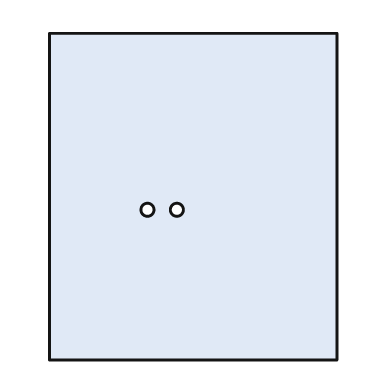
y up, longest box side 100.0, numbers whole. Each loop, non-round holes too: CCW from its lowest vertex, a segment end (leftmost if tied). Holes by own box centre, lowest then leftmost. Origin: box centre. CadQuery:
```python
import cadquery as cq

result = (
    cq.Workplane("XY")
    .moveTo(-44.0, -50.0)
    .lineTo(44.0, -50.0)
    .lineTo(44.0, 50.0)
    .lineTo(-44.0, 50.0)
    .close()
    .moveTo(-14.0, -4.0)
    .circle(2.0)
    .moveTo(-5.0, -4.0)
    .circle(2.0)
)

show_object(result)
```